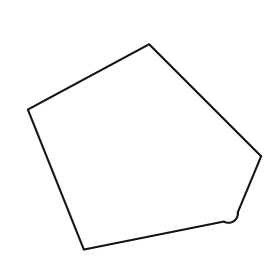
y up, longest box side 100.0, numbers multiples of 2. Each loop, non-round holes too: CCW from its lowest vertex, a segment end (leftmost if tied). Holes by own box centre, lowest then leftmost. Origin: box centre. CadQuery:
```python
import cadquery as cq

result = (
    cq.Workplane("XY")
    .moveTo(-26.0, -44.0)
    .lineTo(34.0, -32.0)
    .threePointArc((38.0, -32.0), (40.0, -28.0))
    .lineTo(50.0, -4.0)
    .lineTo(2.0, 44.0)
    .lineTo(-50.0, 16.0)
    .close()
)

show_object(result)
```